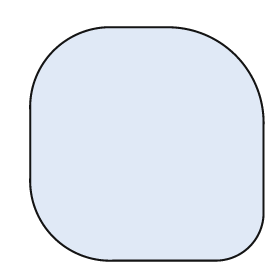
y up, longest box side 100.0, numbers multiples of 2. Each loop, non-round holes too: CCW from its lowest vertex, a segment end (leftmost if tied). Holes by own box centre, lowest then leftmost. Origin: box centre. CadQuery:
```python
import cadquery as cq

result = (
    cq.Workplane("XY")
    .moveTo(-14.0, -50.0)
    .lineTo(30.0, -50.0)
    .threePointArc((44.0, -44.0), (50.0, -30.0))
    .lineTo(50.0, 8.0)
    .threePointArc((38.0, 38.0), (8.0, 50.0))
    .lineTo(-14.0, 50.0)
    .threePointArc((-40.0, 40.0), (-50.0, 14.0))
    .lineTo(-50.0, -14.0)
    .threePointArc((-40.0, -40.0), (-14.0, -50.0))
    .close()
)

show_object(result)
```